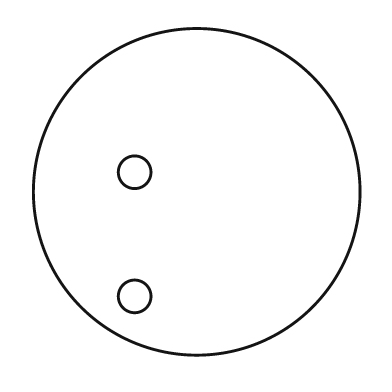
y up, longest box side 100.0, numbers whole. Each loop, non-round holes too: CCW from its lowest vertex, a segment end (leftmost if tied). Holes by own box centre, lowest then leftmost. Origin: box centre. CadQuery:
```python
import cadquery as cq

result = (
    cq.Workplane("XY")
    .moveTo(0.0, 0.0)
    .circle(50.0)
    .moveTo(-19.0, -32.0)
    .circle(5.0)
    .moveTo(-19.0, 6.0)
    .circle(5.0)
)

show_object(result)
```